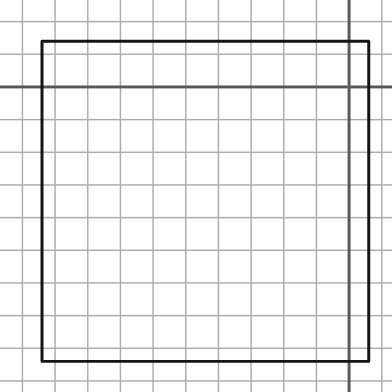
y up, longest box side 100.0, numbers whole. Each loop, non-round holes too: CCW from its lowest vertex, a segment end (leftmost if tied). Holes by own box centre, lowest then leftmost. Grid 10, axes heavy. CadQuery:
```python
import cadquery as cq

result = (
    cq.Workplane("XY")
    .moveTo(-94.0, -84.0)
    .lineTo(6.0, -84.0)
    .lineTo(6.0, 14.0)
    .lineTo(-94.0, 14.0)
    .close()
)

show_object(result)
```